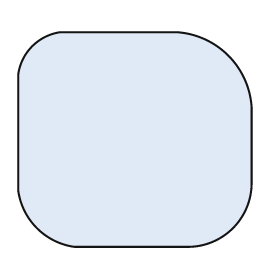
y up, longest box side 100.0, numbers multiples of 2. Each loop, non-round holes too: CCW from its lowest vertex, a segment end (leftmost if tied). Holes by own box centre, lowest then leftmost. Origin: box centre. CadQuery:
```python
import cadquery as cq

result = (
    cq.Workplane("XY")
    .moveTo(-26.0, -46.0)
    .lineTo(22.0, -46.0)
    .threePointArc((42.0, -38.0), (50.0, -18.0))
    .lineTo(50.0, 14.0)
    .threePointArc((40.0, 36.0), (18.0, 46.0))
    .lineTo(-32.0, 46.0)
    .threePointArc((-44.0, 40.0), (-50.0, 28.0))
    .lineTo(-50.0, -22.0)
    .threePointArc((-42.0, -38.0), (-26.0, -46.0))
    .close()
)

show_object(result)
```